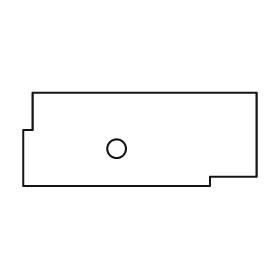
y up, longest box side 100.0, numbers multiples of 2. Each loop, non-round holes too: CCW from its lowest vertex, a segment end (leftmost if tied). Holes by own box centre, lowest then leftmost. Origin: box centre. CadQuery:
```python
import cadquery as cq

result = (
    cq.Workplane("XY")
    .moveTo(-50.0, -20.0)
    .lineTo(30.0, -20.0)
    .lineTo(30.0, -16.0)
    .lineTo(50.0, -16.0)
    .lineTo(50.0, 20.0)
    .lineTo(-46.0, 20.0)
    .lineTo(-46.0, 4.0)
    .lineTo(-50.0, 4.0)
    .close()
    .moveTo(-10.0, -4.0)
    .circle(4.0)
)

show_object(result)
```